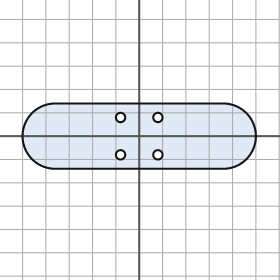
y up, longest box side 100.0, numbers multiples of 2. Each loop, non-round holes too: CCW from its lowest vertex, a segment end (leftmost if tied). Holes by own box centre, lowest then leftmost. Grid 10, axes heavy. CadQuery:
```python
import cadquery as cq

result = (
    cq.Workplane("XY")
    .moveTo(-36.0, -14.0)
    .lineTo(36.0, -14.0)
    .threePointArc((50.0, 0.0), (36.0, 14.0))
    .lineTo(-36.0, 14.0)
    .threePointArc((-50.0, 0.0), (-36.0, -14.0))
    .close()
    .moveTo(-8.0, -8.0)
    .circle(2.0)
    .moveTo(8.0, -8.0)
    .circle(2.0)
    .moveTo(-8.0, 8.0)
    .circle(2.0)
    .moveTo(8.0, 8.0)
    .circle(2.0)
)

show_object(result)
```